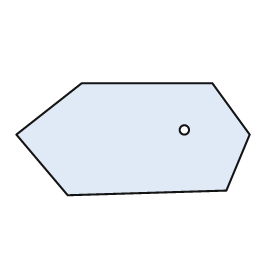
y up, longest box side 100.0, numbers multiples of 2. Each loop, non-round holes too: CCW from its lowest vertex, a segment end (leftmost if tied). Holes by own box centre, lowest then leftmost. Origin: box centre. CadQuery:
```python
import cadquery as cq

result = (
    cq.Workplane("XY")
    .moveTo(-28.0, -24.0)
    .lineTo(40.0, -22.0)
    .lineTo(50.0, 2.0)
    .lineTo(34.0, 24.0)
    .lineTo(-22.0, 24.0)
    .lineTo(-50.0, 2.0)
    .close()
    .moveTo(22.0, 4.0)
    .circle(2.0)
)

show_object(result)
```